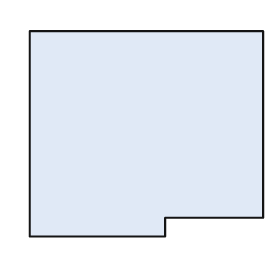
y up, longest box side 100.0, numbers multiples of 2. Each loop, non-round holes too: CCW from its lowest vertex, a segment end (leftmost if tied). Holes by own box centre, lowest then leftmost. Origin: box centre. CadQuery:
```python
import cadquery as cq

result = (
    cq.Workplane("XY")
    .moveTo(-50.0, -44.0)
    .lineTo(8.0, -44.0)
    .lineTo(8.0, -36.0)
    .lineTo(50.0, -36.0)
    .lineTo(50.0, 44.0)
    .lineTo(-50.0, 44.0)
    .close()
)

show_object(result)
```